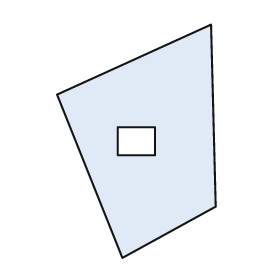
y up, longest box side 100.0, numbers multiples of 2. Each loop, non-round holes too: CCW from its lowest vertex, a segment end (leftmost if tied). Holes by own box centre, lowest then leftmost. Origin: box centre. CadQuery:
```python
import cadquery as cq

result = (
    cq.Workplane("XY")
    .moveTo(-6.0, -50.0)
    .lineTo(34.0, -28.0)
    .lineTo(32.0, 50.0)
    .lineTo(-34.0, 20.0)
    .close()
    .moveTo(-8.0, -6.0)
    .lineTo(8.0, -6.0)
    .lineTo(8.0, 6.0)
    .lineTo(-8.0, 6.0)
    .close()
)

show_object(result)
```